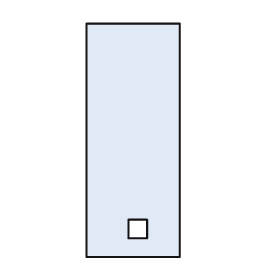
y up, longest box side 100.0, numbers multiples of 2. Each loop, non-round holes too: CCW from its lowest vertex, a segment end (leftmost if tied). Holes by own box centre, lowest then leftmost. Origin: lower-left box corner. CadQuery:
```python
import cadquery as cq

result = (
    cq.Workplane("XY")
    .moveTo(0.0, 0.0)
    .lineTo(40.0, 0.0)
    .lineTo(40.0, 100.0)
    .lineTo(0.0, 100.0)
    .close()
    .moveTo(18.0, 8.0)
    .lineTo(26.0, 8.0)
    .lineTo(26.0, 16.0)
    .lineTo(18.0, 16.0)
    .close()
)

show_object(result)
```